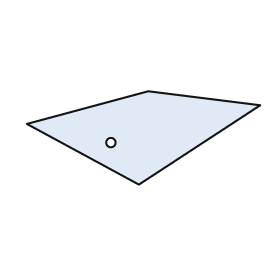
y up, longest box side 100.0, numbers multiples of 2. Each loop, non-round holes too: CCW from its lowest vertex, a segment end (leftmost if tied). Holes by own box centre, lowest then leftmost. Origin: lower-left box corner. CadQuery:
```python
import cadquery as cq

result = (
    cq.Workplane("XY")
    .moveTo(48.0, 0.0)
    .lineTo(100.0, 34.0)
    .lineTo(52.0, 40.0)
    .lineTo(0.0, 26.0)
    .close()
    .moveTo(36.0, 18.0)
    .circle(2.0)
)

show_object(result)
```